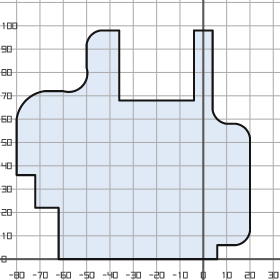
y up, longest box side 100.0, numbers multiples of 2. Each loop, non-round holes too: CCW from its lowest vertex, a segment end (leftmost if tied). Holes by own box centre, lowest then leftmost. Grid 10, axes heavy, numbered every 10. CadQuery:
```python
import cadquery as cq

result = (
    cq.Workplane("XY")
    .moveTo(-62.0, 0.0)
    .lineTo(6.0, 0.0)
    .lineTo(6.0, 6.0)
    .lineTo(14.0, 6.0)
    .threePointArc((18.0, 8.0), (20.0, 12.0))
    .lineTo(20.0, 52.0)
    .threePointArc((18.0, 56.0), (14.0, 58.0))
    .lineTo(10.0, 58.0)
    .threePointArc((6.0, 60.0), (4.0, 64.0))
    .lineTo(4.0, 98.0)
    .lineTo(-4.0, 98.0)
    .lineTo(-4.0, 68.0)
    .lineTo(-36.0, 68.0)
    .lineTo(-36.0, 98.0)
    .lineTo(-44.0, 98.0)
    .threePointArc((-48.0, 96.0), (-50.0, 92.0))
    .lineTo(-50.0, 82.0)
    .threePointArc((-52.0, 74.0), (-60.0, 72.0))
    .lineTo(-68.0, 72.0)
    .threePointArc((-76.0, 68.0), (-80.0, 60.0))
    .lineTo(-80.0, 36.0)
    .lineTo(-72.0, 36.0)
    .lineTo(-72.0, 22.0)
    .lineTo(-62.0, 22.0)
    .close()
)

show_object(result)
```